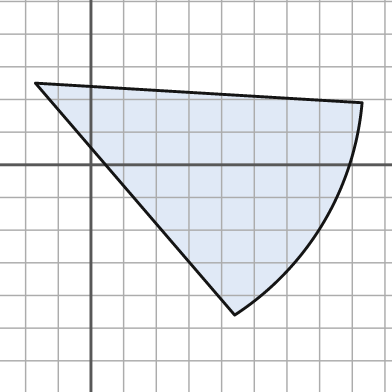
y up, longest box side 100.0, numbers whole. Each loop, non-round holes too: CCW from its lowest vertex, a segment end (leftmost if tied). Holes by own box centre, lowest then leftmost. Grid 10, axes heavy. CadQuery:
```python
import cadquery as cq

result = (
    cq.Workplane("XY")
    .moveTo(44.0, -46.0)
    .threePointArc((71.0, -18.0), (83.0, 19.0))
    .lineTo(-17.0, 25.0)
    .close()
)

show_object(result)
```